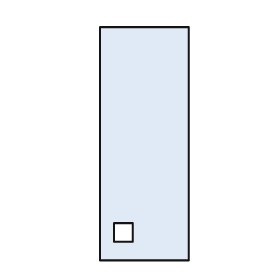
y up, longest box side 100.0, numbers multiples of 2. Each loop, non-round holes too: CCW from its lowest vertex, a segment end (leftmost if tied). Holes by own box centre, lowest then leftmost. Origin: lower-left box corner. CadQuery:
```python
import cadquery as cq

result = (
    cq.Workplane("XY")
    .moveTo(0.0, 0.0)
    .lineTo(38.0, 0.0)
    .lineTo(38.0, 100.0)
    .lineTo(0.0, 100.0)
    .close()
    .moveTo(6.0, 8.0)
    .lineTo(14.0, 8.0)
    .lineTo(14.0, 16.0)
    .lineTo(6.0, 16.0)
    .close()
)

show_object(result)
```